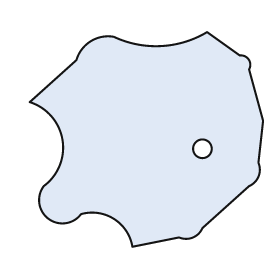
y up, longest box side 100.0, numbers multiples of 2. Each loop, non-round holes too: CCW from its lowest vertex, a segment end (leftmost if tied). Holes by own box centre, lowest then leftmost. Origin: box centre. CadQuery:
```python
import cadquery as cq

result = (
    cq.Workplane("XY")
    .moveTo(-6.0, -46.0)
    .lineTo(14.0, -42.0)
    .threePointArc((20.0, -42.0), (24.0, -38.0))
    .lineTo(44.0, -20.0)
    .threePointArc((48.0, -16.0), (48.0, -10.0))
    .lineTo(50.0, 8.0)
    .lineTo(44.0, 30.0)
    .threePointArc((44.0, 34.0), (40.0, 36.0))
    .lineTo(26.0, 46.0)
    .threePointArc((6.0, 40.0), (-14.0, 44.0))
    .threePointArc((-24.0, 42.0), (-30.0, 34.0))
    .lineTo(-50.0, 16.0)
    .threePointArc((-36.0, 0.0), (-44.0, -20.0))
    .threePointArc((-42.0, -34.0), (-28.0, -32.0))
    .threePointArc((-14.0, -34.0), (-6.0, -46.0))
    .close()
    .moveTo(24.0, -4.0)
    .circle(4.0)
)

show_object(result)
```